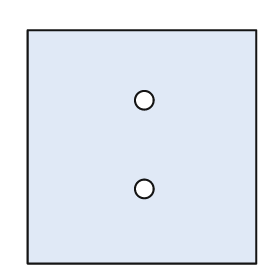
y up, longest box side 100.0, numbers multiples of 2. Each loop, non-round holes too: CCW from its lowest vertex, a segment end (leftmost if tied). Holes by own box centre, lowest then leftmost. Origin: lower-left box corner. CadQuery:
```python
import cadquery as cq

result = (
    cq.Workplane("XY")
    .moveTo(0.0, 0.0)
    .lineTo(98.0, 0.0)
    .lineTo(98.0, 100.0)
    .lineTo(0.0, 100.0)
    .close()
    .moveTo(50.0, 32.0)
    .circle(4.0)
    .moveTo(50.0, 70.0)
    .circle(4.0)
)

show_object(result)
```